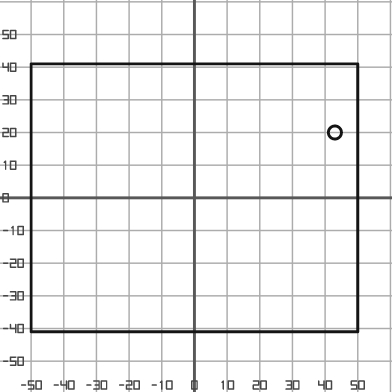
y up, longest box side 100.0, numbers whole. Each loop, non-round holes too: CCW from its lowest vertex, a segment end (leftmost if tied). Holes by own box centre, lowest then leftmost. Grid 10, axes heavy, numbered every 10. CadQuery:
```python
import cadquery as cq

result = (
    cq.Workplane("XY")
    .moveTo(-50.0, -41.0)
    .lineTo(50.0, -41.0)
    .lineTo(50.0, 41.0)
    .lineTo(-50.0, 41.0)
    .close()
    .moveTo(43.0, 20.0)
    .circle(2.0)
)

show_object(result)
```